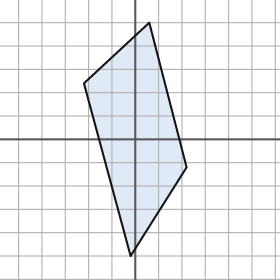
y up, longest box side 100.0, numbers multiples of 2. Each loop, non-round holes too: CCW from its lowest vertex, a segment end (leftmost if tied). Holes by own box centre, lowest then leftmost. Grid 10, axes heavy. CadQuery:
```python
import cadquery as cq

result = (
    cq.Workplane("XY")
    .moveTo(-2.0, -50.0)
    .lineTo(22.0, -12.0)
    .lineTo(6.0, 50.0)
    .lineTo(-22.0, 24.0)
    .close()
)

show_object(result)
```